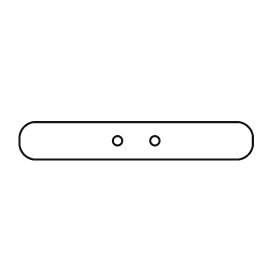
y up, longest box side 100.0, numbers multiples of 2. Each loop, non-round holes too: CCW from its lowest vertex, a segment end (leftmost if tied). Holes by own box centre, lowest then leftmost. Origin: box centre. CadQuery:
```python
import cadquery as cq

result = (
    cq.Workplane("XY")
    .moveTo(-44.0, -8.0)
    .lineTo(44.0, -8.0)
    .threePointArc((48.0, -6.0), (50.0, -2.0))
    .lineTo(50.0, 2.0)
    .threePointArc((48.0, 6.0), (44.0, 8.0))
    .lineTo(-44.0, 8.0)
    .threePointArc((-48.0, 6.0), (-50.0, 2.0))
    .lineTo(-50.0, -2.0)
    .threePointArc((-48.0, -6.0), (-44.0, -8.0))
    .close()
    .moveTo(-8.0, 0.0)
    .circle(2.0)
    .moveTo(8.0, 0.0)
    .circle(2.0)
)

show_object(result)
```